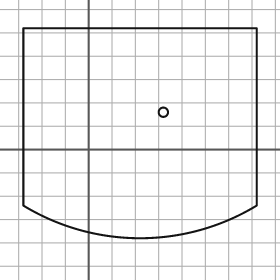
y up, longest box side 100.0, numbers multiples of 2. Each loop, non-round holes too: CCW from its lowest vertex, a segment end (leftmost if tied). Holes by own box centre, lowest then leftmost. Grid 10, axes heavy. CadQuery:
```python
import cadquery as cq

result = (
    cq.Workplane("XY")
    .moveTo(-28.0, -24.0)
    .threePointArc((22.0, -38.0), (72.0, -24.0))
    .lineTo(72.0, 52.0)
    .lineTo(-28.0, 52.0)
    .close()
    .moveTo(32.0, 16.0)
    .circle(2.0)
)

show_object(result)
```